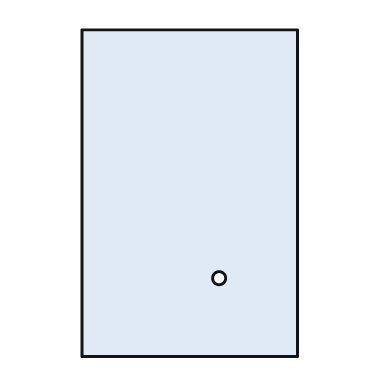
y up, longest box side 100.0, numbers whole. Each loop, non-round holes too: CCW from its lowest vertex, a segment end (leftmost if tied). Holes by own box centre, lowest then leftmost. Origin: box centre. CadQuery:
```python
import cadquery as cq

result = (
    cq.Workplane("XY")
    .moveTo(-33.0, -50.0)
    .lineTo(33.0, -50.0)
    .lineTo(33.0, 50.0)
    .lineTo(-33.0, 50.0)
    .close()
    .moveTo(9.0, -26.0)
    .circle(2.0)
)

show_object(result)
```